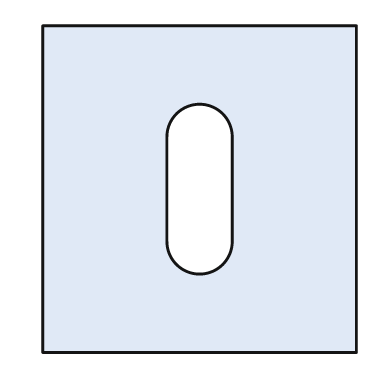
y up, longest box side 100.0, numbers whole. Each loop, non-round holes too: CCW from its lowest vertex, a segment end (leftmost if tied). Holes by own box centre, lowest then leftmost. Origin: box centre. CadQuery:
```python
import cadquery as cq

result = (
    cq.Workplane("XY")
    .moveTo(-48.0, -50.0)
    .lineTo(48.0, -50.0)
    .lineTo(48.0, 50.0)
    .lineTo(-48.0, 50.0)
    .close()
    .moveTo(-10.0, -16.0)
    .threePointArc((0.0, -26.0), (10.0, -16.0))
    .lineTo(10.0, 16.0)
    .threePointArc((0.0, 26.0), (-10.0, 16.0))
    .close()
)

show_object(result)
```